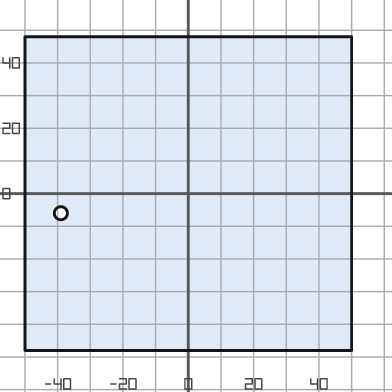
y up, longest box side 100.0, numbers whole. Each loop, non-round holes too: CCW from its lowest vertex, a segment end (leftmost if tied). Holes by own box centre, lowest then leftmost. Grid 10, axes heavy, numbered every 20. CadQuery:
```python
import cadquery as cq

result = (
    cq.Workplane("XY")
    .moveTo(-50.0, -48.0)
    .lineTo(50.0, -48.0)
    .lineTo(50.0, 48.0)
    .lineTo(-50.0, 48.0)
    .close()
    .moveTo(-39.0, -6.0)
    .circle(2.0)
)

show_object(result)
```